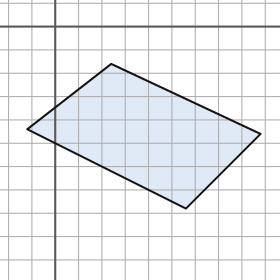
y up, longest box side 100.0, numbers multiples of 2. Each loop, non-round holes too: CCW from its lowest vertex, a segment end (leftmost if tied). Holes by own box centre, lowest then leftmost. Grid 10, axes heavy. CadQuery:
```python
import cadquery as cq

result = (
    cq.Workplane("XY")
    .moveTo(56.0, -78.0)
    .lineTo(88.0, -46.0)
    .lineTo(24.0, -16.0)
    .lineTo(-12.0, -44.0)
    .close()
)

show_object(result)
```